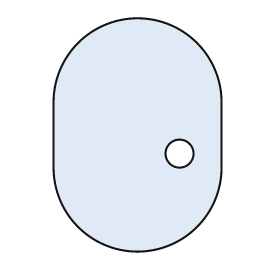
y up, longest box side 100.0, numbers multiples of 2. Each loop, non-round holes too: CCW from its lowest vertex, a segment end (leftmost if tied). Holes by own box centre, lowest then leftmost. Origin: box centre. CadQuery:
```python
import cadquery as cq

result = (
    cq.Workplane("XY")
    .moveTo(-36.0, -14.0)
    .threePointArc((0.0, -50.0), (36.0, -14.0))
    .lineTo(36.0, 14.0)
    .threePointArc((0.0, 50.0), (-36.0, 14.0))
    .close()
    .moveTo(18.0, -8.0)
    .circle(6.0)
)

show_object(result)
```